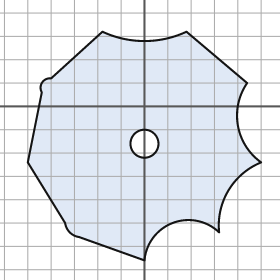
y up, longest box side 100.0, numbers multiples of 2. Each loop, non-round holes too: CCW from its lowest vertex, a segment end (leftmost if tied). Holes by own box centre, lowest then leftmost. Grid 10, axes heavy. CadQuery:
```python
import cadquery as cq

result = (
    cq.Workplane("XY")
    .moveTo(0.0, -66.0)
    .threePointArc((12.0, -50.0), (32.0, -54.0))
    .threePointArc((36.0, -36.0), (50.0, -24.0))
    .threePointArc((40.0, -8.0), (44.0, 10.0))
    .lineTo(18.0, 32.0)
    .threePointArc((0.0, 28.0), (-18.0, 32.0))
    .lineTo(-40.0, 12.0)
    .threePointArc((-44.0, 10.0), (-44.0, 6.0))
    .lineTo(-50.0, -24.0)
    .lineTo(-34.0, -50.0)
    .threePointArc((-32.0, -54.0), (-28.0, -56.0))
    .close()
    .moveTo(0.0, -16.0)
    .circle(6.0)
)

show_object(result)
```